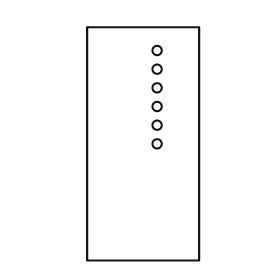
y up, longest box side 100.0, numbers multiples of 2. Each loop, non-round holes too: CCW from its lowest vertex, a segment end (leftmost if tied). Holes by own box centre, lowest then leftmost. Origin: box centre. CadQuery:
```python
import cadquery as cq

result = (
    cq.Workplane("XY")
    .moveTo(-24.0, -50.0)
    .lineTo(24.0, -50.0)
    .lineTo(24.0, 50.0)
    .lineTo(-24.0, 50.0)
    .close()
    .moveTo(6.0, 0.0)
    .circle(2.0)
    .moveTo(6.0, 8.0)
    .circle(2.0)
    .moveTo(6.0, 16.0)
    .circle(2.0)
    .moveTo(6.0, 24.0)
    .circle(2.0)
    .moveTo(6.0, 32.0)
    .circle(2.0)
    .moveTo(6.0, 40.0)
    .circle(2.0)
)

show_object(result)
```